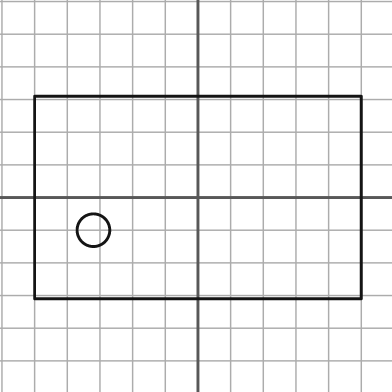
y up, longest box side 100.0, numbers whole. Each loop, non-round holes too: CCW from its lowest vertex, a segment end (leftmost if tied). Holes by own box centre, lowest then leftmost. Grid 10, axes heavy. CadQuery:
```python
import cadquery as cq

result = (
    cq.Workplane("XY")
    .moveTo(-50.0, -31.0)
    .lineTo(50.0, -31.0)
    .lineTo(50.0, 31.0)
    .lineTo(-50.0, 31.0)
    .close()
    .moveTo(-32.0, -10.0)
    .circle(5.0)
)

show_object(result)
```